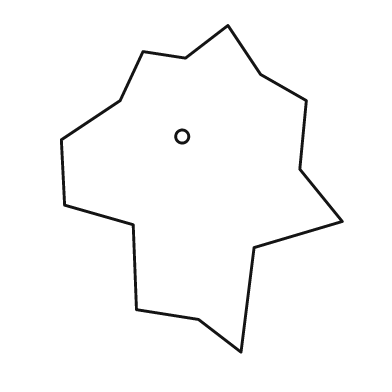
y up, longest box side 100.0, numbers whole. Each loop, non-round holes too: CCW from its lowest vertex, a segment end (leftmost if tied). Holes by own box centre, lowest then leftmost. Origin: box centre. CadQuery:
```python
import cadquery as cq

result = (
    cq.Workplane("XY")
    .moveTo(12.0, -50.0)
    .lineTo(16.0, -18.0)
    .lineTo(43.0, -10.0)
    .lineTo(30.0, 6.0)
    .lineTo(32.0, 27.0)
    .lineTo(18.0, 35.0)
    .lineTo(8.0, 50.0)
    .lineTo(-5.0, 40.0)
    .lineTo(-18.0, 42.0)
    .lineTo(-25.0, 27.0)
    .lineTo(-43.0, 15.0)
    .lineTo(-42.0, -5.0)
    .lineTo(-21.0, -11.0)
    .lineTo(-20.0, -37.0)
    .lineTo(-1.0, -40.0)
    .close()
    .moveTo(-6.0, 16.0)
    .circle(2.0)
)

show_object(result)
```